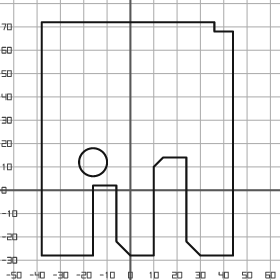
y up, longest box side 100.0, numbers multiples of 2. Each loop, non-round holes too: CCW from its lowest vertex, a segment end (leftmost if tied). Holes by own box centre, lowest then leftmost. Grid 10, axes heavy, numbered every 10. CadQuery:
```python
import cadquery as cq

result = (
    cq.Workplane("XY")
    .moveTo(-38.0, -28.0)
    .lineTo(-16.0, -28.0)
    .lineTo(-16.0, 2.0)
    .lineTo(-6.0, 2.0)
    .lineTo(-6.0, -22.0)
    .lineTo(0.0, -28.0)
    .lineTo(10.0, -28.0)
    .lineTo(10.0, 10.0)
    .lineTo(14.0, 14.0)
    .lineTo(24.0, 14.0)
    .lineTo(24.0, -22.0)
    .lineTo(30.0, -28.0)
    .lineTo(44.0, -28.0)
    .lineTo(44.0, 68.0)
    .lineTo(36.0, 68.0)
    .lineTo(36.0, 72.0)
    .lineTo(-38.0, 72.0)
    .close()
    .moveTo(-16.0, 12.0)
    .circle(6.0)
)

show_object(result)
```